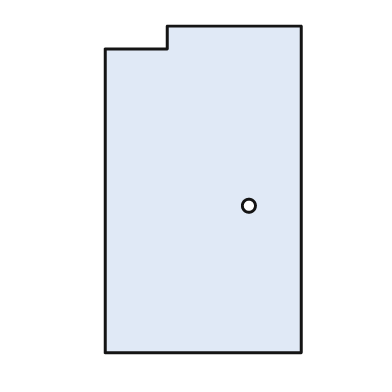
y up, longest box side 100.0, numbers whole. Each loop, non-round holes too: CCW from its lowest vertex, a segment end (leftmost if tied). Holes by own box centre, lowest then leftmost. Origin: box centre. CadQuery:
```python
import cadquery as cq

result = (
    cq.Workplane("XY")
    .moveTo(-30.0, -50.0)
    .lineTo(30.0, -50.0)
    .lineTo(30.0, 50.0)
    .lineTo(-11.0, 50.0)
    .lineTo(-11.0, 43.0)
    .lineTo(-30.0, 43.0)
    .close()
    .moveTo(14.0, -5.0)
    .circle(2.0)
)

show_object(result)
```